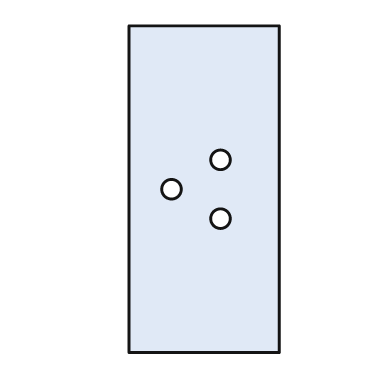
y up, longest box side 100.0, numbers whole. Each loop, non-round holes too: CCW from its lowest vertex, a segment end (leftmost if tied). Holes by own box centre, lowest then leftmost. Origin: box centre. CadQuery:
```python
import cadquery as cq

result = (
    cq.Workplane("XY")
    .moveTo(-23.0, -50.0)
    .lineTo(23.0, -50.0)
    .lineTo(23.0, 50.0)
    .lineTo(-23.0, 50.0)
    .close()
    .moveTo(5.0, -9.0)
    .circle(3.0)
    .moveTo(-10.0, 0.0)
    .circle(3.0)
    .moveTo(5.0, 9.0)
    .circle(3.0)
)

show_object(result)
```